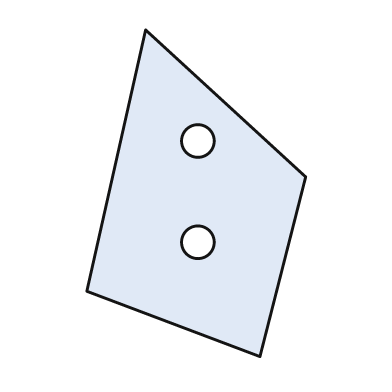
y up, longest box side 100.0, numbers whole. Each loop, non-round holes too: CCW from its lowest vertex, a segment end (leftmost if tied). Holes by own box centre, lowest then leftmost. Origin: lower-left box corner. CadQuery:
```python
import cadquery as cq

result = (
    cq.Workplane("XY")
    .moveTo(53.0, 0.0)
    .lineTo(67.0, 55.0)
    .lineTo(18.0, 100.0)
    .lineTo(0.0, 20.0)
    .close()
    .moveTo(34.0, 35.0)
    .circle(5.0)
    .moveTo(34.0, 66.0)
    .circle(5.0)
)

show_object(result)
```